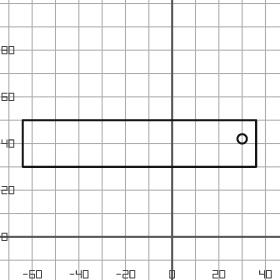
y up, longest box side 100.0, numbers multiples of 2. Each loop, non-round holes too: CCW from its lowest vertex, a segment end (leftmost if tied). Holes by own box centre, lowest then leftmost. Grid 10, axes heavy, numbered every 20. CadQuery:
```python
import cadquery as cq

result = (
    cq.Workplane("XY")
    .moveTo(-64.0, 30.0)
    .lineTo(36.0, 30.0)
    .lineTo(36.0, 50.0)
    .lineTo(-64.0, 50.0)
    .close()
    .moveTo(30.0, 42.0)
    .circle(2.0)
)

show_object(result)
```